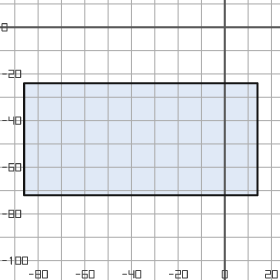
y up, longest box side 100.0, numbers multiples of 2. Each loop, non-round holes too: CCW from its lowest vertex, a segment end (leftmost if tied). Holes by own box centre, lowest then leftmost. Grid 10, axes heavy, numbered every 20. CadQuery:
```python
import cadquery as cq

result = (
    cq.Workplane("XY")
    .moveTo(-86.0, -72.0)
    .lineTo(14.0, -72.0)
    .lineTo(14.0, -24.0)
    .lineTo(-86.0, -24.0)
    .close()
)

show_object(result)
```